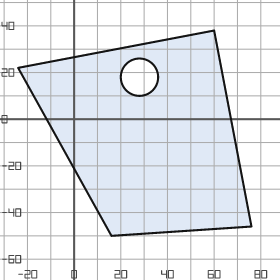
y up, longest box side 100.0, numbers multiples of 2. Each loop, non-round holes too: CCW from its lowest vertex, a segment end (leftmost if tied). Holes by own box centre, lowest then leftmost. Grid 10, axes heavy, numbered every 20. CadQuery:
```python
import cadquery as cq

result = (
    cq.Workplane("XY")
    .moveTo(16.0, -50.0)
    .lineTo(76.0, -46.0)
    .lineTo(60.0, 38.0)
    .lineTo(-24.0, 22.0)
    .close()
    .moveTo(28.0, 18.0)
    .circle(8.0)
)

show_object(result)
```